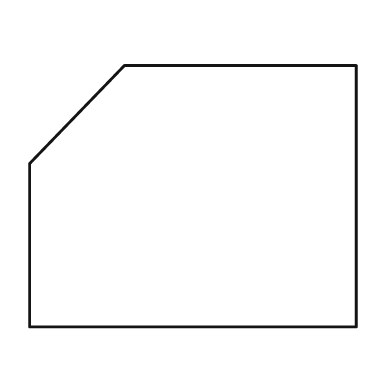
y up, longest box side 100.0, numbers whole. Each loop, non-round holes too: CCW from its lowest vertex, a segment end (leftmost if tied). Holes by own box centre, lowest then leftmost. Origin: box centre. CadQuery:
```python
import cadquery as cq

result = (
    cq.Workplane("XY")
    .moveTo(-50.0, -40.0)
    .lineTo(50.0, -40.0)
    .lineTo(50.0, 40.0)
    .lineTo(-21.0, 40.0)
    .lineTo(-50.0, 10.0)
    .close()
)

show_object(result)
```